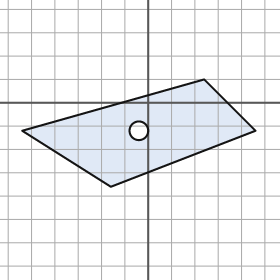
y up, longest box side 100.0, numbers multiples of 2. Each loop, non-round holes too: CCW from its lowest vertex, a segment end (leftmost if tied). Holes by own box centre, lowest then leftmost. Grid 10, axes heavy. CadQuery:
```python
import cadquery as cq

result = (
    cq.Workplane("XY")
    .moveTo(-16.0, -36.0)
    .lineTo(46.0, -12.0)
    .lineTo(24.0, 10.0)
    .lineTo(-54.0, -12.0)
    .close()
    .moveTo(-4.0, -12.0)
    .circle(4.0)
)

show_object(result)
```